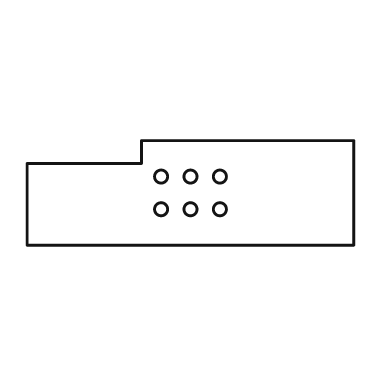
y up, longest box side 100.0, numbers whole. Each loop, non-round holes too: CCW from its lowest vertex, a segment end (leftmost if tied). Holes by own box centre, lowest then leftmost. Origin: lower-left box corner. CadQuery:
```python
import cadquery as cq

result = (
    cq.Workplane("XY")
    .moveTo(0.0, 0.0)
    .lineTo(100.0, 0.0)
    .lineTo(100.0, 32.0)
    .lineTo(35.0, 32.0)
    .lineTo(35.0, 25.0)
    .lineTo(0.0, 25.0)
    .close()
    .moveTo(41.0, 11.0)
    .circle(2.0)
    .moveTo(50.0, 11.0)
    .circle(2.0)
    .moveTo(59.0, 11.0)
    .circle(2.0)
    .moveTo(41.0, 21.0)
    .circle(2.0)
    .moveTo(50.0, 21.0)
    .circle(2.0)
    .moveTo(59.0, 21.0)
    .circle(2.0)
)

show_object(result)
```